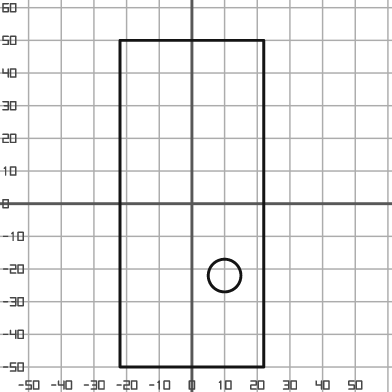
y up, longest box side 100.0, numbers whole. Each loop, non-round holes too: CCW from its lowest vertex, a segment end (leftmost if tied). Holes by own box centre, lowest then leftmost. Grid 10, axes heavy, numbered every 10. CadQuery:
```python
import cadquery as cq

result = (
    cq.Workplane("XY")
    .moveTo(-22.0, -50.0)
    .lineTo(22.0, -50.0)
    .lineTo(22.0, 50.0)
    .lineTo(-22.0, 50.0)
    .close()
    .moveTo(10.0, -22.0)
    .circle(5.0)
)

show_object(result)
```